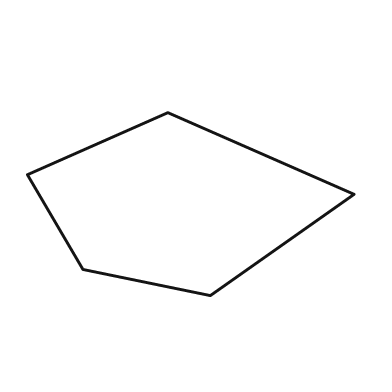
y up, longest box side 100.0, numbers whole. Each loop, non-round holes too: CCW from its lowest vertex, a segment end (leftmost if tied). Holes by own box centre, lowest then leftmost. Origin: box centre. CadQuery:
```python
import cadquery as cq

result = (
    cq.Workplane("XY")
    .moveTo(6.0, -28.0)
    .lineTo(50.0, 3.0)
    .lineTo(-7.0, 28.0)
    .lineTo(-50.0, 9.0)
    .lineTo(-33.0, -20.0)
    .close()
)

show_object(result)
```